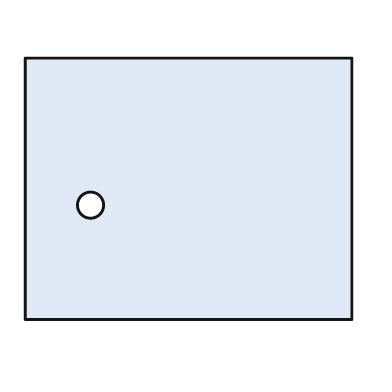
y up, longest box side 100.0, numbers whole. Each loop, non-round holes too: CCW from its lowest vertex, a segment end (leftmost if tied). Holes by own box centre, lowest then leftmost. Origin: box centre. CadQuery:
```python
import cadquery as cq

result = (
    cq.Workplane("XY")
    .moveTo(-50.0, -40.0)
    .lineTo(50.0, -40.0)
    .lineTo(50.0, 40.0)
    .lineTo(-50.0, 40.0)
    .close()
    .moveTo(-30.0, -5.0)
    .circle(4.0)
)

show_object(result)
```